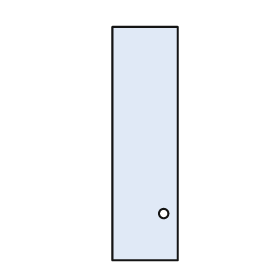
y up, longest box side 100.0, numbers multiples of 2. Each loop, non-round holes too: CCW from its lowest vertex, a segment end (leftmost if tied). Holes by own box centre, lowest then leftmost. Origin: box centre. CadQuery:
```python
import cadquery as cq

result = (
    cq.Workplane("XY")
    .moveTo(-14.0, -50.0)
    .lineTo(14.0, -50.0)
    .lineTo(14.0, 50.0)
    .lineTo(-14.0, 50.0)
    .close()
    .moveTo(8.0, -30.0)
    .circle(2.0)
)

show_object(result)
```